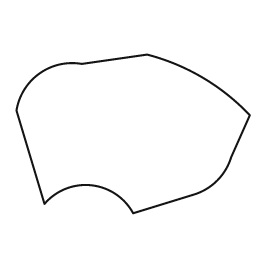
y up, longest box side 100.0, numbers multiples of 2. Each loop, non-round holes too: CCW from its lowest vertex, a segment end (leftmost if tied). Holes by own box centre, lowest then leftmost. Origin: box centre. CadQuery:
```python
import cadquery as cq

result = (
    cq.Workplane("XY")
    .moveTo(0.0, -34.0)
    .lineTo(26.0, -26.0)
    .threePointArc((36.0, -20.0), (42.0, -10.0))
    .lineTo(50.0, 8.0)
    .threePointArc((30.0, 24.0), (6.0, 34.0))
    .lineTo(-22.0, 30.0)
    .threePointArc((-40.0, 26.0), (-50.0, 10.0))
    .lineTo(-38.0, -30.0)
    .threePointArc((-18.0, -22.0), (0.0, -34.0))
    .close()
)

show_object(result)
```